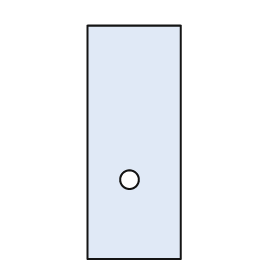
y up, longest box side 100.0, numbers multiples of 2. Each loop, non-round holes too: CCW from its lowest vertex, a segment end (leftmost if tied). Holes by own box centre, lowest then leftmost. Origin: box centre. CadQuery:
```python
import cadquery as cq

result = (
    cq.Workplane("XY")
    .moveTo(-20.0, -50.0)
    .lineTo(20.0, -50.0)
    .lineTo(20.0, 50.0)
    .lineTo(-20.0, 50.0)
    .close()
    .moveTo(-2.0, -16.0)
    .circle(4.0)
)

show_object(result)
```